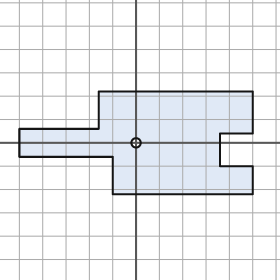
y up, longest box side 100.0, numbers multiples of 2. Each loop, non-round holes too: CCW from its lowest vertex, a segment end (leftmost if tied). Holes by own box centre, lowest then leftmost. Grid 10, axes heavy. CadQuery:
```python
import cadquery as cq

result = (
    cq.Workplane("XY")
    .moveTo(-10.0, -22.0)
    .lineTo(50.0, -22.0)
    .lineTo(50.0, -10.0)
    .lineTo(36.0, -10.0)
    .lineTo(36.0, 4.0)
    .lineTo(50.0, 4.0)
    .lineTo(50.0, 22.0)
    .lineTo(-16.0, 22.0)
    .lineTo(-16.0, 6.0)
    .lineTo(-50.0, 6.0)
    .lineTo(-50.0, -6.0)
    .lineTo(-10.0, -6.0)
    .close()
    .moveTo(0.0, 0.0)
    .circle(2.0)
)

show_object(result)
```